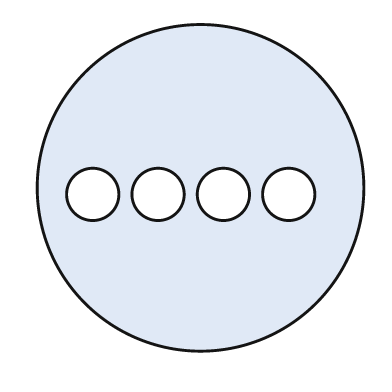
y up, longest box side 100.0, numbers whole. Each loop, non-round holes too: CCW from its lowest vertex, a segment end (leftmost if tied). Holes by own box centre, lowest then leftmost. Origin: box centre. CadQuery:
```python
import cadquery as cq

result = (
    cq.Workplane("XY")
    .moveTo(0.0, 0.0)
    .circle(50.0)
    .moveTo(-33.0, -2.0)
    .circle(8.0)
    .moveTo(-13.0, -2.0)
    .circle(8.0)
    .moveTo(7.0, -2.0)
    .circle(8.0)
    .moveTo(27.0, -2.0)
    .circle(8.0)
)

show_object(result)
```